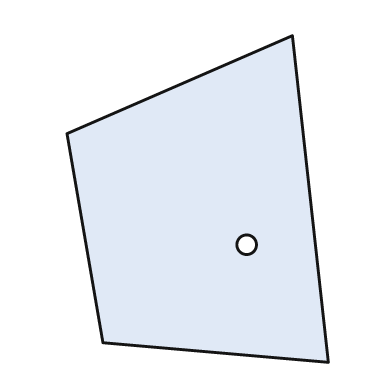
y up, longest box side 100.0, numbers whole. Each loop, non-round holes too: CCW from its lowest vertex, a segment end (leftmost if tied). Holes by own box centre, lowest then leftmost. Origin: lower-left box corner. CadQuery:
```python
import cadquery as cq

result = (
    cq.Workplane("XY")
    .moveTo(80.0, 0.0)
    .lineTo(69.0, 100.0)
    .lineTo(0.0, 70.0)
    .lineTo(11.0, 6.0)
    .close()
    .moveTo(55.0, 36.0)
    .circle(3.0)
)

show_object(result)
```